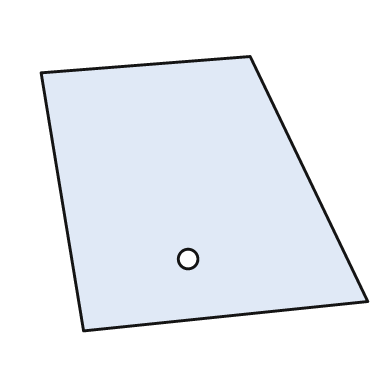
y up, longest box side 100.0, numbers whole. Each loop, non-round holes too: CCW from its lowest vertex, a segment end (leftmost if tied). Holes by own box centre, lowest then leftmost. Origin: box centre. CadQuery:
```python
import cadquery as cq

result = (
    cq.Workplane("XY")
    .moveTo(-37.0, -42.0)
    .lineTo(50.0, -33.0)
    .lineTo(14.0, 42.0)
    .lineTo(-50.0, 37.0)
    .close()
    .moveTo(-5.0, -20.0)
    .circle(3.0)
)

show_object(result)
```